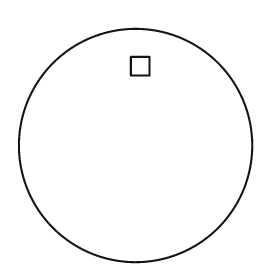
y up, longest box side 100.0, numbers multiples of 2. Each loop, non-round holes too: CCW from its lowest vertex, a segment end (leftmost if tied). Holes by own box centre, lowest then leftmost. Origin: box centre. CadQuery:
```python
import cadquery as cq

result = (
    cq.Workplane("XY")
    .moveTo(0.0, 0.0)
    .circle(50.0)
    .moveTo(-2.0, 30.0)
    .lineTo(6.0, 30.0)
    .lineTo(6.0, 38.0)
    .lineTo(-2.0, 38.0)
    .close()
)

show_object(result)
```